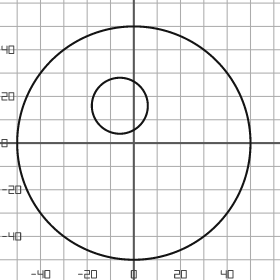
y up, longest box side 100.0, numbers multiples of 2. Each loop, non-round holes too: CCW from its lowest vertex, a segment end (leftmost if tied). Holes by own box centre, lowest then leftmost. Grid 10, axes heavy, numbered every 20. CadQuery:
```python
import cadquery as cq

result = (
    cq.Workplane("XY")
    .moveTo(0.0, 0.0)
    .circle(50.0)
    .moveTo(-6.0, 16.0)
    .circle(12.0)
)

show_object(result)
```